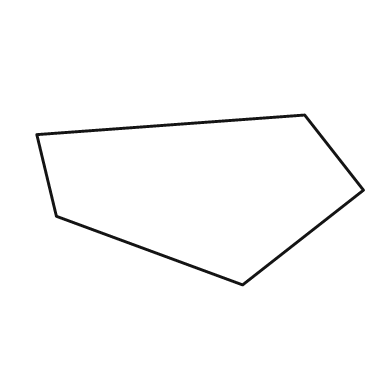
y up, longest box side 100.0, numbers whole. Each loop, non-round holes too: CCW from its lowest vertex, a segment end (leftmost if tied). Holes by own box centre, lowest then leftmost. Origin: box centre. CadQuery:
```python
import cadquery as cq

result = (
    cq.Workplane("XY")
    .moveTo(13.0, -26.0)
    .lineTo(50.0, 3.0)
    .lineTo(32.0, 26.0)
    .lineTo(-50.0, 20.0)
    .lineTo(-44.0, -5.0)
    .close()
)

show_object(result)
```